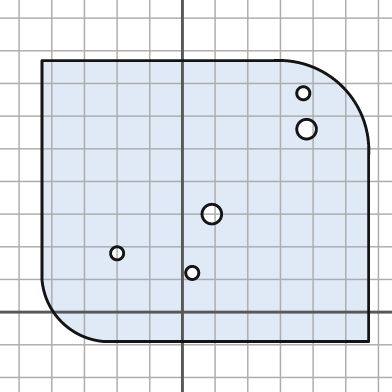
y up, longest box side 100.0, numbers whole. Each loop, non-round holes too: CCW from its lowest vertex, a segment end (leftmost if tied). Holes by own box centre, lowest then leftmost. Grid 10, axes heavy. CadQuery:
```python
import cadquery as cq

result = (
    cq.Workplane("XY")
    .moveTo(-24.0, -9.0)
    .lineTo(57.0, -9.0)
    .lineTo(57.0, 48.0)
    .threePointArc((49.0, 69.0), (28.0, 77.0))
    .lineTo(-43.0, 77.0)
    .lineTo(-43.0, 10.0)
    .threePointArc((-37.0, -3.0), (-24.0, -9.0))
    .close()
    .moveTo(3.0, 12.0)
    .circle(2.0)
    .moveTo(-20.0, 18.0)
    .circle(2.0)
    .moveTo(9.0, 30.0)
    .circle(3.0)
    .moveTo(38.0, 56.0)
    .circle(3.0)
    .moveTo(37.0, 67.0)
    .circle(2.0)
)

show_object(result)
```